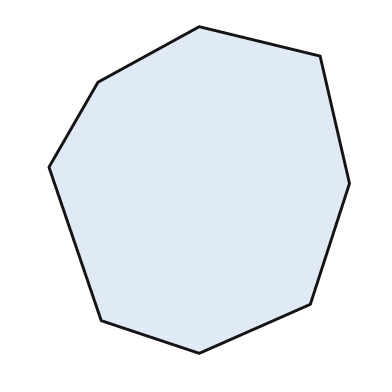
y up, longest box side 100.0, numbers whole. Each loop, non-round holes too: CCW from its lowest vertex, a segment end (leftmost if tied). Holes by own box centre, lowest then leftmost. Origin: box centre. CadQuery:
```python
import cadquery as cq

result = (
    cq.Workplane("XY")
    .moveTo(0.0, -50.0)
    .lineTo(34.0, -35.0)
    .lineTo(46.0, 2.0)
    .lineTo(37.0, 41.0)
    .lineTo(0.0, 50.0)
    .lineTo(-31.0, 33.0)
    .lineTo(-46.0, 7.0)
    .lineTo(-30.0, -40.0)
    .close()
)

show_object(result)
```